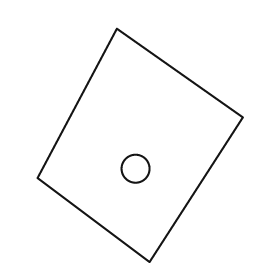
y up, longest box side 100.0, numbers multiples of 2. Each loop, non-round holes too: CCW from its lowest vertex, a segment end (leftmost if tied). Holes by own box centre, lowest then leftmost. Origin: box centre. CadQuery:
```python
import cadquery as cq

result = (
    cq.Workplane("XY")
    .moveTo(4.0, -50.0)
    .lineTo(44.0, 12.0)
    .lineTo(-10.0, 50.0)
    .lineTo(-44.0, -14.0)
    .close()
    .moveTo(-2.0, -10.0)
    .circle(6.0)
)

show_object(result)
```